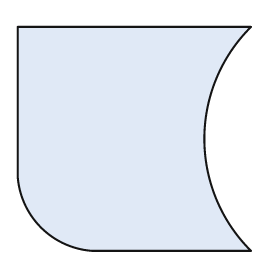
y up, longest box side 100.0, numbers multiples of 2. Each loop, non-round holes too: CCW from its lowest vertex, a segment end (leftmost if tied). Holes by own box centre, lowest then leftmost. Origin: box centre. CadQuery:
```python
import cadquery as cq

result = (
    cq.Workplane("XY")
    .moveTo(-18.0, -48.0)
    .lineTo(50.0, -48.0)
    .threePointArc((30.0, 0.0), (50.0, 48.0))
    .lineTo(-50.0, 48.0)
    .lineTo(-50.0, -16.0)
    .threePointArc((-40.0, -38.0), (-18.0, -48.0))
    .close()
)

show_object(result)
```